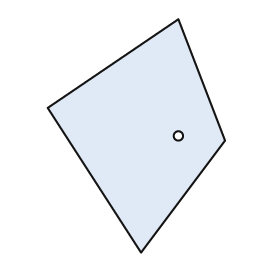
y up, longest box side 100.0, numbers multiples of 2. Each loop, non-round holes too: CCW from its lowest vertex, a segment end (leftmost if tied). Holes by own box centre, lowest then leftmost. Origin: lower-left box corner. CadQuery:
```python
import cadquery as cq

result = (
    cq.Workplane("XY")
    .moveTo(40.0, 0.0)
    .lineTo(76.0, 48.0)
    .lineTo(56.0, 100.0)
    .lineTo(0.0, 62.0)
    .close()
    .moveTo(56.0, 50.0)
    .circle(2.0)
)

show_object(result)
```